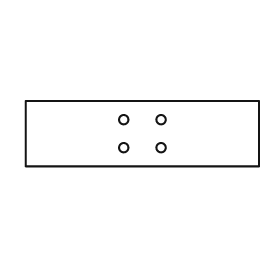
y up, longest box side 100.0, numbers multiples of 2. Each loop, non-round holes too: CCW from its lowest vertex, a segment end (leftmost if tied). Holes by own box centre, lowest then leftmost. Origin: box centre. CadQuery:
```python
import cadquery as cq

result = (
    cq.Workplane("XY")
    .moveTo(-50.0, -14.0)
    .lineTo(50.0, -14.0)
    .lineTo(50.0, 14.0)
    .lineTo(-50.0, 14.0)
    .close()
    .moveTo(-8.0, -6.0)
    .circle(2.0)
    .moveTo(8.0, -6.0)
    .circle(2.0)
    .moveTo(-8.0, 6.0)
    .circle(2.0)
    .moveTo(8.0, 6.0)
    .circle(2.0)
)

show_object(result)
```